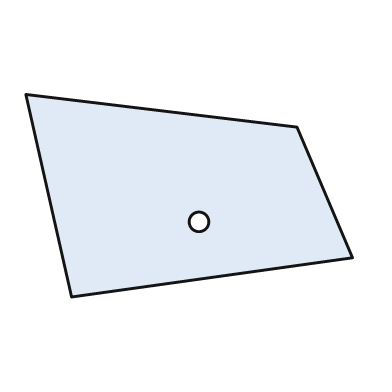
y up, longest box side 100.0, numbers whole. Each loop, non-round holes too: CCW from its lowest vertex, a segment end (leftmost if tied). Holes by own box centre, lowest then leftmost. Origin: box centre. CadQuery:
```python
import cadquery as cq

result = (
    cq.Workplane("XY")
    .moveTo(-36.0, -31.0)
    .lineTo(50.0, -19.0)
    .lineTo(33.0, 21.0)
    .lineTo(-50.0, 31.0)
    .close()
    .moveTo(3.0, -8.0)
    .circle(3.0)
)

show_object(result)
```